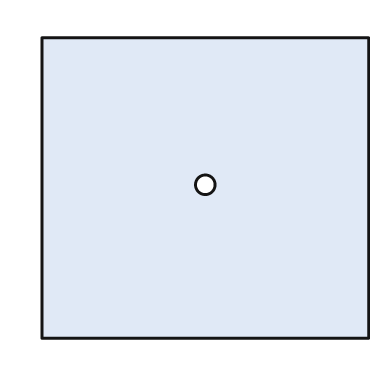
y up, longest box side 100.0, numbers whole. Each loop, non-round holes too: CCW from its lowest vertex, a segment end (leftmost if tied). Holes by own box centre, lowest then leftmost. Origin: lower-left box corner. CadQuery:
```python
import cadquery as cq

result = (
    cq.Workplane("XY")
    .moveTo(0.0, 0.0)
    .lineTo(100.0, 0.0)
    .lineTo(100.0, 92.0)
    .lineTo(0.0, 92.0)
    .close()
    .moveTo(50.0, 47.0)
    .circle(3.0)
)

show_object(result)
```